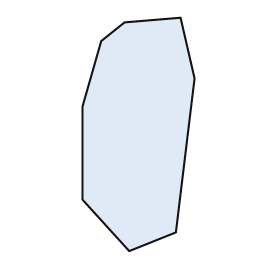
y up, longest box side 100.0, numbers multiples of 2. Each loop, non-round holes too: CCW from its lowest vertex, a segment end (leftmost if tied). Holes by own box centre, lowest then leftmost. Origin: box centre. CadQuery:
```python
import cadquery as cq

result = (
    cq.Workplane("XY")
    .moveTo(-4.0, -50.0)
    .lineTo(16.0, -42.0)
    .lineTo(24.0, 24.0)
    .lineTo(18.0, 50.0)
    .lineTo(-6.0, 48.0)
    .lineTo(-16.0, 40.0)
    .lineTo(-24.0, 12.0)
    .lineTo(-24.0, -28.0)
    .close()
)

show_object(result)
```